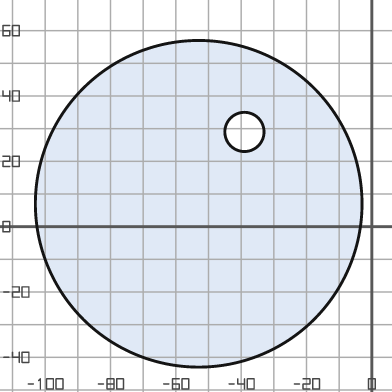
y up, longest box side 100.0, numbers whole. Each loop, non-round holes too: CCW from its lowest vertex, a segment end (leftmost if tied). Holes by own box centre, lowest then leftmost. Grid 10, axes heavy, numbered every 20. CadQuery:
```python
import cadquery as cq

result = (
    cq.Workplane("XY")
    .moveTo(-53.0, 7.0)
    .circle(50.0)
    .moveTo(-39.0, 29.0)
    .circle(6.0)
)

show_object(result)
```